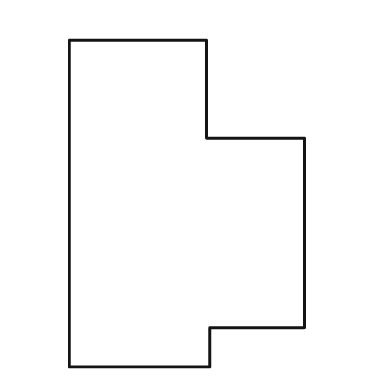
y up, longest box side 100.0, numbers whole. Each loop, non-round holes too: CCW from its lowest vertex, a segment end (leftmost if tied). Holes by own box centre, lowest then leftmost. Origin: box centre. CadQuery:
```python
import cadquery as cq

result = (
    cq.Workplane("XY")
    .moveTo(-36.0, -50.0)
    .lineTo(7.0, -50.0)
    .lineTo(7.0, -38.0)
    .lineTo(36.0, -38.0)
    .lineTo(36.0, 20.0)
    .lineTo(6.0, 20.0)
    .lineTo(6.0, 50.0)
    .lineTo(-36.0, 50.0)
    .close()
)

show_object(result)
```